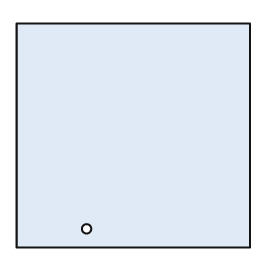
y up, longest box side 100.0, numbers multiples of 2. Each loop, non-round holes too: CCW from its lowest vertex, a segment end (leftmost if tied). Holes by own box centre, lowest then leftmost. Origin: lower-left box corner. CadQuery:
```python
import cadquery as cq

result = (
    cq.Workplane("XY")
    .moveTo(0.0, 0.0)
    .lineTo(100.0, 0.0)
    .lineTo(100.0, 96.0)
    .lineTo(0.0, 96.0)
    .close()
    .moveTo(30.0, 8.0)
    .circle(2.0)
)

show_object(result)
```